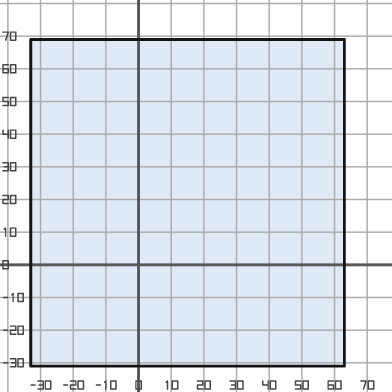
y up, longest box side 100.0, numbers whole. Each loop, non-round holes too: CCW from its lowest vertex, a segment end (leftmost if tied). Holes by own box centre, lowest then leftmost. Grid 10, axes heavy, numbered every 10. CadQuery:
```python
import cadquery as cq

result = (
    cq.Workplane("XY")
    .moveTo(-33.0, -31.0)
    .lineTo(63.0, -31.0)
    .lineTo(63.0, 69.0)
    .lineTo(-33.0, 69.0)
    .close()
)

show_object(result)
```